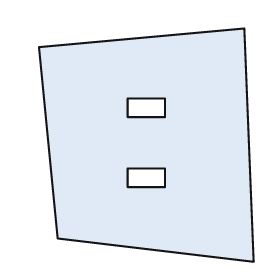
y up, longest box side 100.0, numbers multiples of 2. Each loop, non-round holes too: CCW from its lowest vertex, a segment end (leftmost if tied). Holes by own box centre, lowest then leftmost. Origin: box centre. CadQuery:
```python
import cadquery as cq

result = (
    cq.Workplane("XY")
    .moveTo(46.0, -50.0)
    .lineTo(42.0, 50.0)
    .lineTo(-46.0, 42.0)
    .lineTo(-38.0, -40.0)
    .close()
    .moveTo(-8.0, -18.0)
    .lineTo(8.0, -18.0)
    .lineTo(8.0, -10.0)
    .lineTo(-8.0, -10.0)
    .close()
    .moveTo(-8.0, 12.0)
    .lineTo(8.0, 12.0)
    .lineTo(8.0, 20.0)
    .lineTo(-8.0, 20.0)
    .close()
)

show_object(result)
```